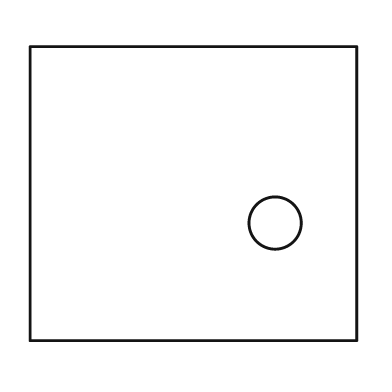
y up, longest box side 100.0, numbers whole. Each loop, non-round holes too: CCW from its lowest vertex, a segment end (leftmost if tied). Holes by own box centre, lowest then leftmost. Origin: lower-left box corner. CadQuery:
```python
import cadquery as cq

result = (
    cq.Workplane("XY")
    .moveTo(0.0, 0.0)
    .lineTo(100.0, 0.0)
    .lineTo(100.0, 90.0)
    .lineTo(0.0, 90.0)
    .close()
    .moveTo(75.0, 36.0)
    .circle(8.0)
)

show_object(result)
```